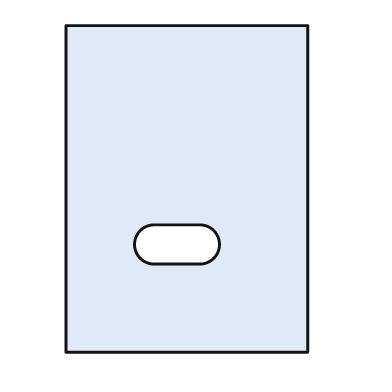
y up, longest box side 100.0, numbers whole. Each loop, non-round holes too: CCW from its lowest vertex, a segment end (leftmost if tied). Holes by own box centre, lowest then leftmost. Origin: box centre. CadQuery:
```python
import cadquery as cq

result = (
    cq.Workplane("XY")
    .moveTo(-37.0, -50.0)
    .lineTo(37.0, -50.0)
    .lineTo(37.0, 50.0)
    .lineTo(-37.0, 50.0)
    .close()
    .moveTo(-10.0, -23.0)
    .lineTo(4.0, -23.0)
    .threePointArc((10.0, -17.0), (4.0, -11.0))
    .lineTo(-10.0, -11.0)
    .threePointArc((-16.0, -17.0), (-10.0, -23.0))
    .close()
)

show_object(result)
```